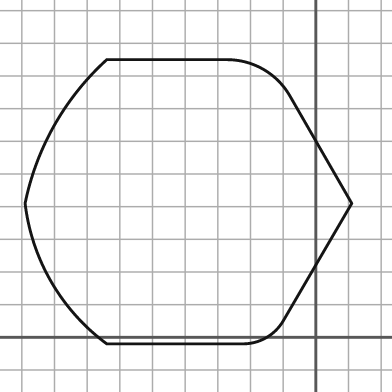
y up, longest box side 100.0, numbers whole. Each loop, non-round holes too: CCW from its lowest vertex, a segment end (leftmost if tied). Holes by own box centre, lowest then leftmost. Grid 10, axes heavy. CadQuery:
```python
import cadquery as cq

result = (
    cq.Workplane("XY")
    .moveTo(-64.0, -2.0)
    .lineTo(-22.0, -2.0)
    .threePointArc((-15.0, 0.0), (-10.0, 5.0))
    .lineTo(11.0, 41.0)
    .lineTo(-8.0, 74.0)
    .threePointArc((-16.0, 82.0), (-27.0, 85.0))
    .lineTo(-64.0, 85.0)
    .threePointArc((-80.0, 65.0), (-89.0, 41.0))
    .threePointArc((-81.0, 17.0), (-64.0, -2.0))
    .close()
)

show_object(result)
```